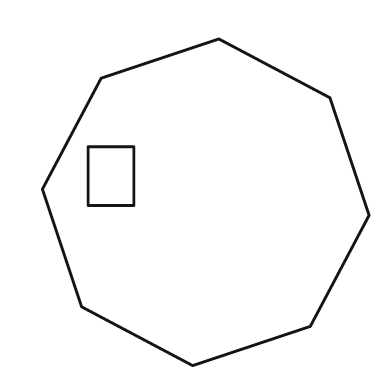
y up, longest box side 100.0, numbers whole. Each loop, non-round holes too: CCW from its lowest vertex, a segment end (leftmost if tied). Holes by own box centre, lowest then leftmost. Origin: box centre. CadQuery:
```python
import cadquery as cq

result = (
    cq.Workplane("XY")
    .moveTo(-4.0, -50.0)
    .lineTo(32.0, -38.0)
    .lineTo(50.0, -4.0)
    .lineTo(38.0, 32.0)
    .lineTo(4.0, 50.0)
    .lineTo(-32.0, 38.0)
    .lineTo(-50.0, 4.0)
    .lineTo(-38.0, -32.0)
    .close()
    .moveTo(-36.0, -1.0)
    .lineTo(-22.0, -1.0)
    .lineTo(-22.0, 17.0)
    .lineTo(-36.0, 17.0)
    .close()
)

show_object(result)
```